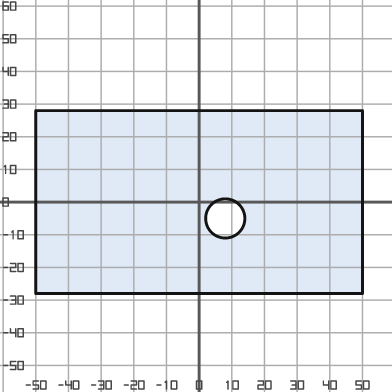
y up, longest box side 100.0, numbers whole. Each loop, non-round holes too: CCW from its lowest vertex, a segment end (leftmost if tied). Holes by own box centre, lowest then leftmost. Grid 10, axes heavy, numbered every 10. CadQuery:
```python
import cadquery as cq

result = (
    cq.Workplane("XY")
    .moveTo(-50.0, -28.0)
    .lineTo(50.0, -28.0)
    .lineTo(50.0, 28.0)
    .lineTo(-50.0, 28.0)
    .close()
    .moveTo(8.0, -5.0)
    .circle(6.0)
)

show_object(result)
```